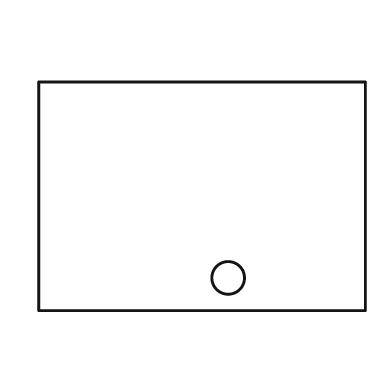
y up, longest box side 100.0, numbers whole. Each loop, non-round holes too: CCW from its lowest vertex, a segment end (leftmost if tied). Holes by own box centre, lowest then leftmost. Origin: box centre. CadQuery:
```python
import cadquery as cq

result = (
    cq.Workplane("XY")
    .moveTo(-50.0, -35.0)
    .lineTo(50.0, -35.0)
    .lineTo(50.0, 35.0)
    .lineTo(-50.0, 35.0)
    .close()
    .moveTo(8.0, -25.0)
    .circle(5.0)
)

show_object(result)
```